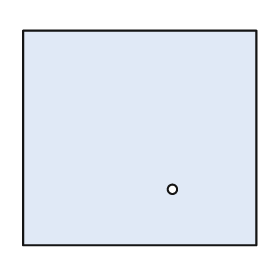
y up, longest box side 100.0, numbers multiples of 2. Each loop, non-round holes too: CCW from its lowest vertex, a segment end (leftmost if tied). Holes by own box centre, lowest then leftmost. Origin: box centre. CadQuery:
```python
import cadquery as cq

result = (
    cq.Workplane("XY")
    .moveTo(-50.0, -46.0)
    .lineTo(50.0, -46.0)
    .lineTo(50.0, 46.0)
    .lineTo(-50.0, 46.0)
    .close()
    .moveTo(14.0, -22.0)
    .circle(2.0)
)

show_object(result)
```